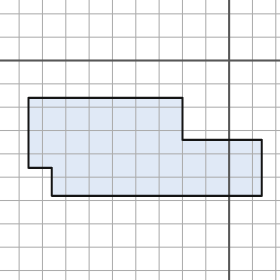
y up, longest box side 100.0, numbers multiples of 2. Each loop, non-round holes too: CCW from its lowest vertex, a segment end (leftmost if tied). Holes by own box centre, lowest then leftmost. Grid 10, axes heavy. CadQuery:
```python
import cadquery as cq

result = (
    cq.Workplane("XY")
    .moveTo(-76.0, -58.0)
    .lineTo(14.0, -58.0)
    .lineTo(14.0, -34.0)
    .lineTo(-20.0, -34.0)
    .lineTo(-20.0, -16.0)
    .lineTo(-86.0, -16.0)
    .lineTo(-86.0, -46.0)
    .lineTo(-76.0, -46.0)
    .close()
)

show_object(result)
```